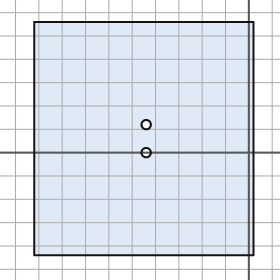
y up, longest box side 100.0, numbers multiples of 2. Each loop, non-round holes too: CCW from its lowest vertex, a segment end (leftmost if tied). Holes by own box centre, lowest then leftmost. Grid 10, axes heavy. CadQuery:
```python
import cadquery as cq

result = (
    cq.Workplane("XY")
    .moveTo(-92.0, -44.0)
    .lineTo(2.0, -44.0)
    .lineTo(2.0, 56.0)
    .lineTo(-92.0, 56.0)
    .close()
    .moveTo(-44.0, 0.0)
    .circle(2.0)
    .moveTo(-44.0, 12.0)
    .circle(2.0)
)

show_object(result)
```